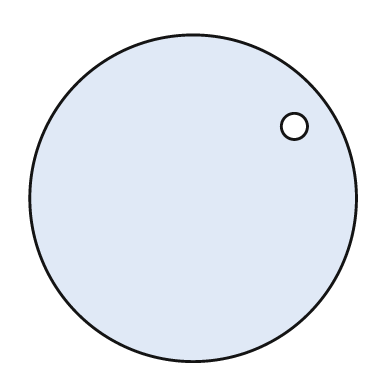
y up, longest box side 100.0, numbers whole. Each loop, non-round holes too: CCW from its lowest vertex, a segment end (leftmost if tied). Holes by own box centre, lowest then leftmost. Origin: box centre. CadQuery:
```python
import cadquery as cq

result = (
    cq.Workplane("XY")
    .moveTo(0.0, 0.0)
    .circle(50.0)
    .moveTo(31.0, 22.0)
    .circle(4.0)
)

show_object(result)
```